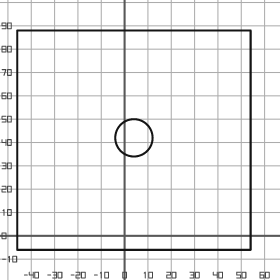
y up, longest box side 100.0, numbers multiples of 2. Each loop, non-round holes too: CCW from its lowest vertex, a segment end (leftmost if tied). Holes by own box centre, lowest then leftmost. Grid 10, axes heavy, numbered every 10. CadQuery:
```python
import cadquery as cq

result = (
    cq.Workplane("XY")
    .moveTo(-46.0, -6.0)
    .lineTo(54.0, -6.0)
    .lineTo(54.0, 88.0)
    .lineTo(-46.0, 88.0)
    .close()
    .moveTo(4.0, 42.0)
    .circle(8.0)
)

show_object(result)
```